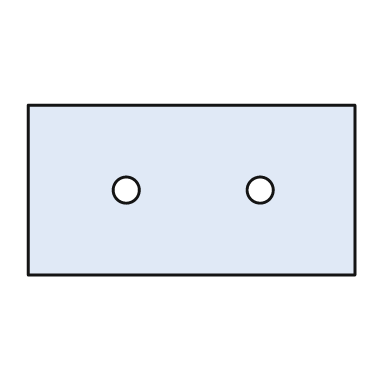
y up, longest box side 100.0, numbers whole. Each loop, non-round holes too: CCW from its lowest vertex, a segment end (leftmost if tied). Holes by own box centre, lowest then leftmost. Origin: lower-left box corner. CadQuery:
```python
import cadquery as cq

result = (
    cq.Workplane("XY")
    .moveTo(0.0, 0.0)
    .lineTo(100.0, 0.0)
    .lineTo(100.0, 52.0)
    .lineTo(0.0, 52.0)
    .close()
    .moveTo(30.0, 26.0)
    .circle(4.0)
    .moveTo(71.0, 26.0)
    .circle(4.0)
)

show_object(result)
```